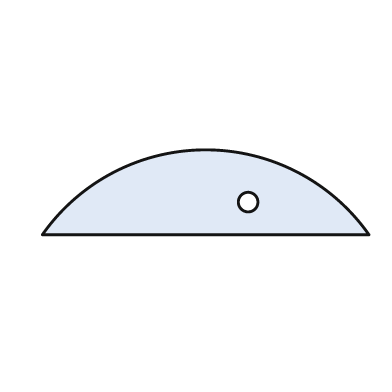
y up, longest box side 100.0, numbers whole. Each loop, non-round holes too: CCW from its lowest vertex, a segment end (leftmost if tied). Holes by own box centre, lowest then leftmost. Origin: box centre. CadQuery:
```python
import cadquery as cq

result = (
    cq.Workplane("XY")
    .moveTo(-50.0, -13.0)
    .lineTo(50.0, -13.0)
    .threePointArc((0.0, 13.0), (-50.0, -13.0))
    .close()
    .moveTo(13.0, -3.0)
    .circle(3.0)
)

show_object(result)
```